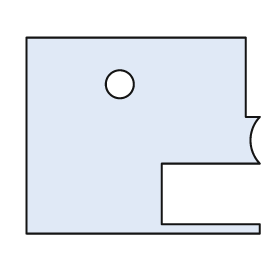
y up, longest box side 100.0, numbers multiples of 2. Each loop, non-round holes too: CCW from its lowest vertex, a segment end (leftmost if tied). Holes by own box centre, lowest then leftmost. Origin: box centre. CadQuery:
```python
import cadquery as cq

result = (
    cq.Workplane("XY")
    .moveTo(-50.0, -42.0)
    .lineTo(50.0, -42.0)
    .lineTo(50.0, -38.0)
    .lineTo(8.0, -38.0)
    .lineTo(8.0, -12.0)
    .lineTo(50.0, -12.0)
    .threePointArc((46.0, -2.0), (50.0, 8.0))
    .lineTo(44.0, 8.0)
    .lineTo(44.0, 42.0)
    .lineTo(-50.0, 42.0)
    .close()
    .moveTo(-10.0, 22.0)
    .circle(6.0)
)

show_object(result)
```